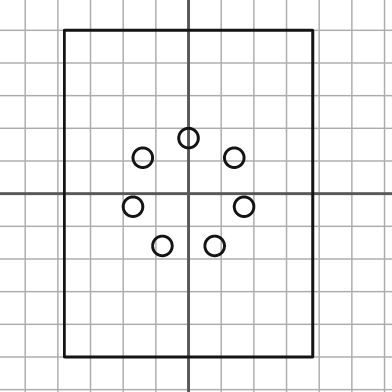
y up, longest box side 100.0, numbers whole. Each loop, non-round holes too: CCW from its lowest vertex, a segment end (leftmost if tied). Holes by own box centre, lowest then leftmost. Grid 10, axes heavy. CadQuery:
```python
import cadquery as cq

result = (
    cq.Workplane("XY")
    .moveTo(-38.0, -50.0)
    .lineTo(38.0, -50.0)
    .lineTo(38.0, 50.0)
    .lineTo(-38.0, 50.0)
    .close()
    .moveTo(-8.0, -16.0)
    .circle(3.0)
    .moveTo(8.0, -16.0)
    .circle(3.0)
    .moveTo(-17.0, -4.0)
    .circle(3.0)
    .moveTo(17.0, -4.0)
    .circle(3.0)
    .moveTo(-14.0, 11.0)
    .circle(3.0)
    .moveTo(14.0, 11.0)
    .circle(3.0)
    .moveTo(0.0, 17.0)
    .circle(3.0)
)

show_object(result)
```